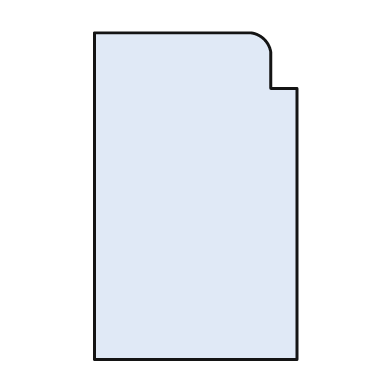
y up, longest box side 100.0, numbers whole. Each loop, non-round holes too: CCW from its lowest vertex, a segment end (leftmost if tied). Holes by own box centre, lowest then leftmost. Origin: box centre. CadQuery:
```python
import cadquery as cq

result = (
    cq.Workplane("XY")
    .moveTo(-31.0, -50.0)
    .lineTo(31.0, -50.0)
    .lineTo(31.0, 33.0)
    .lineTo(23.0, 33.0)
    .lineTo(23.0, 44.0)
    .threePointArc((21.0, 48.0), (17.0, 50.0))
    .lineTo(-31.0, 50.0)
    .close()
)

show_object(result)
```